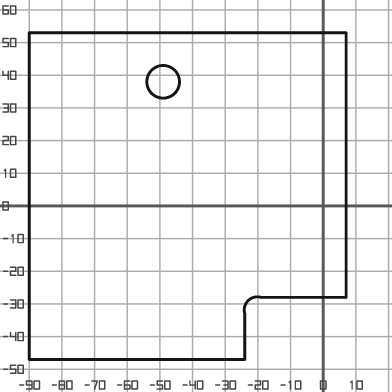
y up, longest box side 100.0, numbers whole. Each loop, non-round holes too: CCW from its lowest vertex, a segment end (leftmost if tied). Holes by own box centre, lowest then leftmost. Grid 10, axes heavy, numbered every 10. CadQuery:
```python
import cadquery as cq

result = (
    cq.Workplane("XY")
    .moveTo(-90.0, -47.0)
    .lineTo(-24.0, -47.0)
    .lineTo(-24.0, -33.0)
    .threePointArc((-23.0, -29.0), (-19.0, -28.0))
    .lineTo(7.0, -28.0)
    .lineTo(7.0, 53.0)
    .lineTo(-90.0, 53.0)
    .close()
    .moveTo(-49.0, 38.0)
    .circle(5.0)
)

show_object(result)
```